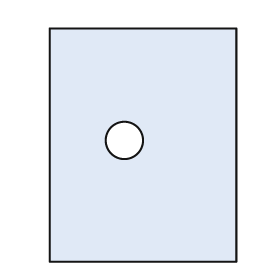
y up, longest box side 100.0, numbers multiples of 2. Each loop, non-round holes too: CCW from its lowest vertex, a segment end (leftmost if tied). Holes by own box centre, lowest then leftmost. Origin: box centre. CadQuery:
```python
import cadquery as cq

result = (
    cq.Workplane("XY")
    .moveTo(-40.0, -50.0)
    .lineTo(40.0, -50.0)
    .lineTo(40.0, 50.0)
    .lineTo(-40.0, 50.0)
    .close()
    .moveTo(-8.0, 2.0)
    .circle(8.0)
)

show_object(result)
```